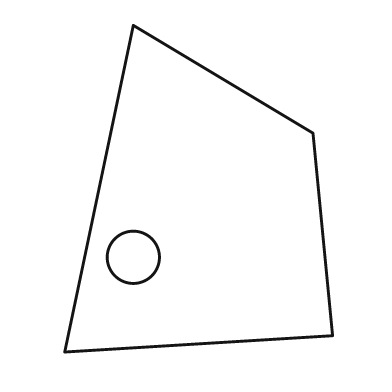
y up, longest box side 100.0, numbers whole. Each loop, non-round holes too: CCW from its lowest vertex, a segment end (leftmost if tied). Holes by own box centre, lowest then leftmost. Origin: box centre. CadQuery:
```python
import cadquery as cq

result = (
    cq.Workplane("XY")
    .moveTo(-41.0, -50.0)
    .lineTo(41.0, -45.0)
    .lineTo(35.0, 17.0)
    .lineTo(-20.0, 50.0)
    .close()
    .moveTo(-20.0, -21.0)
    .circle(8.0)
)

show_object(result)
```